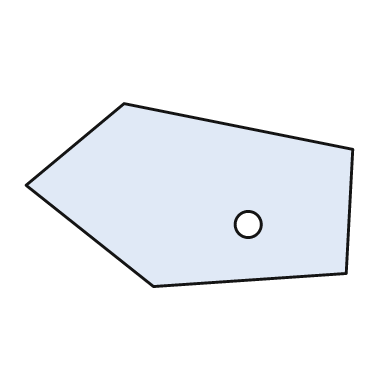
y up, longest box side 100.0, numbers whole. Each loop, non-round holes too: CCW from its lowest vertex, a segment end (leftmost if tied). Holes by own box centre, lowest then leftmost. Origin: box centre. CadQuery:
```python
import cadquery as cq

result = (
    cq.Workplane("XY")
    .moveTo(-11.0, -28.0)
    .lineTo(48.0, -24.0)
    .lineTo(50.0, 14.0)
    .lineTo(-20.0, 28.0)
    .lineTo(-50.0, 3.0)
    .close()
    .moveTo(18.0, -9.0)
    .circle(4.0)
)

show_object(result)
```